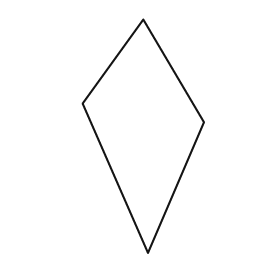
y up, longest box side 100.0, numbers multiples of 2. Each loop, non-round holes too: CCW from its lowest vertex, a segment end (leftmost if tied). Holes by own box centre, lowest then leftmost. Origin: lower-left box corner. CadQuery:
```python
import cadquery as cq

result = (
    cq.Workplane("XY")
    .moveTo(28.0, 0.0)
    .lineTo(52.0, 56.0)
    .lineTo(26.0, 100.0)
    .lineTo(0.0, 64.0)
    .close()
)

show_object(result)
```